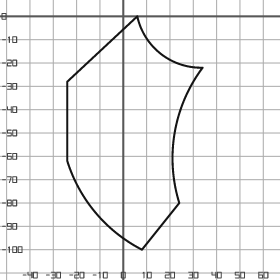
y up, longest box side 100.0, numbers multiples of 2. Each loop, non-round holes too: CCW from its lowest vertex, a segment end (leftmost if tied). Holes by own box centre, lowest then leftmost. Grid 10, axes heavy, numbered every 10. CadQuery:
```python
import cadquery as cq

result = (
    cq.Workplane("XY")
    .moveTo(8.0, -100.0)
    .lineTo(24.0, -80.0)
    .threePointArc((22.0, -50.0), (34.0, -22.0))
    .threePointArc((16.0, -16.0), (6.0, 0.0))
    .lineTo(-24.0, -28.0)
    .lineTo(-24.0, -62.0)
    .threePointArc((-12.0, -84.0), (8.0, -100.0))
    .close()
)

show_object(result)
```